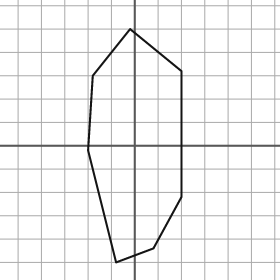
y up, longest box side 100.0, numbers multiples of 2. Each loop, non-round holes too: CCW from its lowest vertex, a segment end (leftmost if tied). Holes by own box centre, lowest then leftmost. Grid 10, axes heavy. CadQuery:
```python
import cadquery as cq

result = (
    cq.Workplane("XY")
    .moveTo(-8.0, -50.0)
    .lineTo(8.0, -44.0)
    .lineTo(20.0, -22.0)
    .lineTo(20.0, 32.0)
    .lineTo(-2.0, 50.0)
    .lineTo(-18.0, 30.0)
    .lineTo(-20.0, -2.0)
    .close()
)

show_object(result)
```